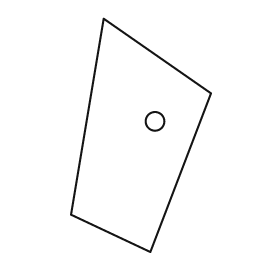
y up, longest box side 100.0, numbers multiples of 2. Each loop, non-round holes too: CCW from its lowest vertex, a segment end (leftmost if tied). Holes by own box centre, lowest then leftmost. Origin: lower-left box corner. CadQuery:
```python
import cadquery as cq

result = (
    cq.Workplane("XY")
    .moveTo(34.0, 0.0)
    .lineTo(60.0, 68.0)
    .lineTo(14.0, 100.0)
    .lineTo(0.0, 16.0)
    .close()
    .moveTo(36.0, 56.0)
    .circle(4.0)
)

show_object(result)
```